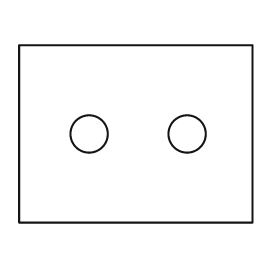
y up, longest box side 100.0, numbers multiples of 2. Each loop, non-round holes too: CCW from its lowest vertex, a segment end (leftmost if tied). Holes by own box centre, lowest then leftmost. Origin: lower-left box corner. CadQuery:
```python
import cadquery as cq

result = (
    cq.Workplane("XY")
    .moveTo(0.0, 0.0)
    .lineTo(100.0, 0.0)
    .lineTo(100.0, 76.0)
    .lineTo(0.0, 76.0)
    .close()
    .moveTo(30.0, 38.0)
    .circle(8.0)
    .moveTo(72.0, 38.0)
    .circle(8.0)
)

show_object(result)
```